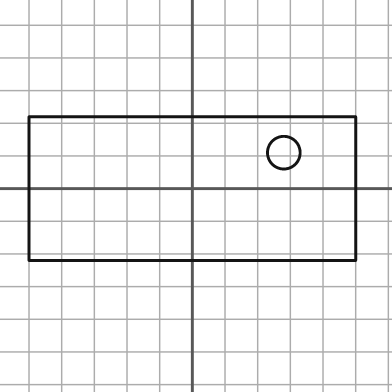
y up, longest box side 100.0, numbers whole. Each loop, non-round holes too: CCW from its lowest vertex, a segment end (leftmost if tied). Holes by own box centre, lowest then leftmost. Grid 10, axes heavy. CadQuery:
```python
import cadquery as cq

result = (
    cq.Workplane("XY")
    .moveTo(-50.0, -22.0)
    .lineTo(50.0, -22.0)
    .lineTo(50.0, 22.0)
    .lineTo(-50.0, 22.0)
    .close()
    .moveTo(28.0, 11.0)
    .circle(5.0)
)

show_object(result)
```